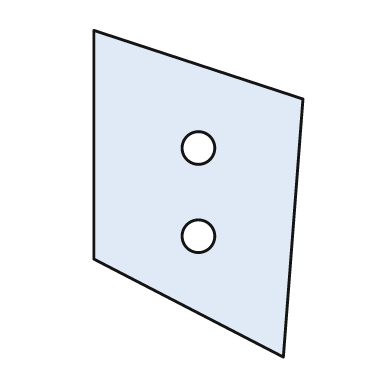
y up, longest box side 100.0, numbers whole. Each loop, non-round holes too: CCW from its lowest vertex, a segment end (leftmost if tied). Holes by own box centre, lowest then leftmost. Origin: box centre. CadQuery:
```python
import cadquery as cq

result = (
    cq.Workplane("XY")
    .moveTo(26.0, -50.0)
    .lineTo(32.0, 29.0)
    .lineTo(-32.0, 50.0)
    .lineTo(-32.0, -20.0)
    .close()
    .moveTo(0.0, -13.0)
    .circle(5.0)
    .moveTo(0.0, 14.0)
    .circle(5.0)
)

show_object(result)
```